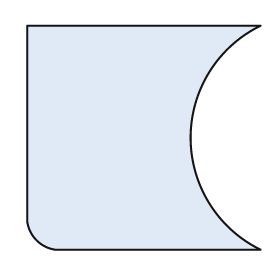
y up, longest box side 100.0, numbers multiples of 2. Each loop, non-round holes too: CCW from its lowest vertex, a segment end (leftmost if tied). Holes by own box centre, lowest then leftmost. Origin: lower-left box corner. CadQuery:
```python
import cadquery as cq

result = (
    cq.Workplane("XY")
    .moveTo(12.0, 0.0)
    .lineTo(100.0, 0.0)
    .threePointArc((70.0, 48.0), (100.0, 96.0))
    .lineTo(0.0, 96.0)
    .lineTo(0.0, 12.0)
    .threePointArc((4.0, 4.0), (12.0, 0.0))
    .close()
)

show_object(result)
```